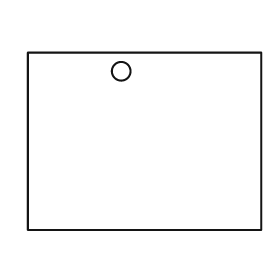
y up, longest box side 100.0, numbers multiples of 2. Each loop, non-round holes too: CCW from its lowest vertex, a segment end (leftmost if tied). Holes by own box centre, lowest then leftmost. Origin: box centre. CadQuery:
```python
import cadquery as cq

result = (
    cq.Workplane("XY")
    .moveTo(-50.0, -38.0)
    .lineTo(50.0, -38.0)
    .lineTo(50.0, 38.0)
    .lineTo(-50.0, 38.0)
    .close()
    .moveTo(-10.0, 30.0)
    .circle(4.0)
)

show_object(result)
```